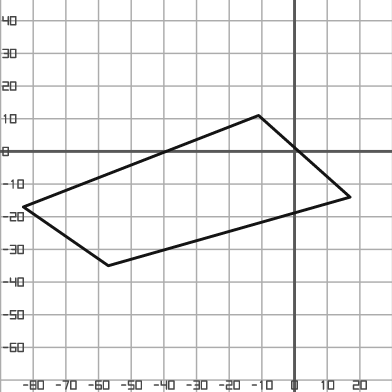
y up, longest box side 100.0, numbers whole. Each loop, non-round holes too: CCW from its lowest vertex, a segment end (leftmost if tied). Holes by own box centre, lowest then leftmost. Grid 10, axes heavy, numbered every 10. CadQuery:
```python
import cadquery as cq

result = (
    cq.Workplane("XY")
    .moveTo(-57.0, -35.0)
    .lineTo(17.0, -14.0)
    .lineTo(-11.0, 11.0)
    .lineTo(-83.0, -17.0)
    .close()
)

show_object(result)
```